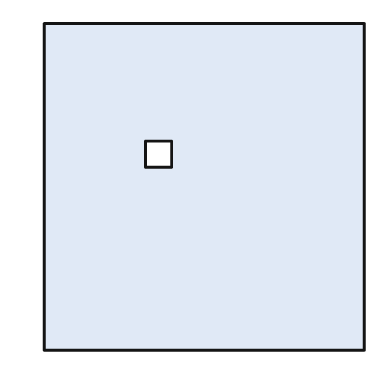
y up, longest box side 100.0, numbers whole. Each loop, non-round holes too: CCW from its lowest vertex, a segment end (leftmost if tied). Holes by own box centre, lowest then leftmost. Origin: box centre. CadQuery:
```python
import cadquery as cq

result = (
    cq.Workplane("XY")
    .moveTo(-49.0, -50.0)
    .lineTo(49.0, -50.0)
    .lineTo(49.0, 50.0)
    .lineTo(-49.0, 50.0)
    .close()
    .moveTo(-18.0, 6.0)
    .lineTo(-10.0, 6.0)
    .lineTo(-10.0, 14.0)
    .lineTo(-18.0, 14.0)
    .close()
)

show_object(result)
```